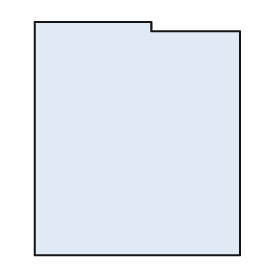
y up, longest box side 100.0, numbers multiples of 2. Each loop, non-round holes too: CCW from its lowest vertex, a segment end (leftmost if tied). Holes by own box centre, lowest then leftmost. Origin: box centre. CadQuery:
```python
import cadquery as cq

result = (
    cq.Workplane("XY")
    .moveTo(-44.0, -50.0)
    .lineTo(44.0, -50.0)
    .lineTo(44.0, 46.0)
    .lineTo(6.0, 46.0)
    .lineTo(6.0, 50.0)
    .lineTo(-44.0, 50.0)
    .close()
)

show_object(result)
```